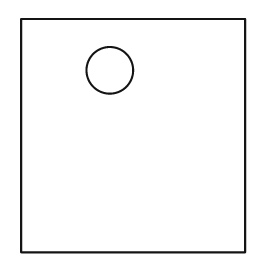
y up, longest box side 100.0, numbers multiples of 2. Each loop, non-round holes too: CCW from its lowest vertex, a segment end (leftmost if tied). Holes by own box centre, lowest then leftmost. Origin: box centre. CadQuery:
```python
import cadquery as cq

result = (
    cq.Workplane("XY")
    .moveTo(-48.0, -50.0)
    .lineTo(48.0, -50.0)
    .lineTo(48.0, 50.0)
    .lineTo(-48.0, 50.0)
    .close()
    .moveTo(-10.0, 28.0)
    .circle(10.0)
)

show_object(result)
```